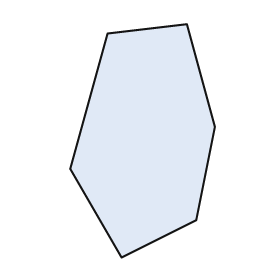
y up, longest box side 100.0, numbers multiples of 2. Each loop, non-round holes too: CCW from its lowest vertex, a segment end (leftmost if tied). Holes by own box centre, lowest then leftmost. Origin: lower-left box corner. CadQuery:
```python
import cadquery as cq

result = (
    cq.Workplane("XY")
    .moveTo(22.0, 0.0)
    .lineTo(54.0, 16.0)
    .lineTo(62.0, 56.0)
    .lineTo(50.0, 100.0)
    .lineTo(16.0, 96.0)
    .lineTo(0.0, 38.0)
    .close()
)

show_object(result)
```